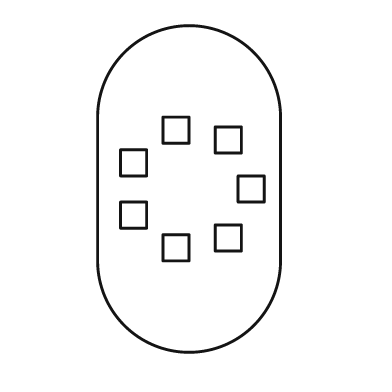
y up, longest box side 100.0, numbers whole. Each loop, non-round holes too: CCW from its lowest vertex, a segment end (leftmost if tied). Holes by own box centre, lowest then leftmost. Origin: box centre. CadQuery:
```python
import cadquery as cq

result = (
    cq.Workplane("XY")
    .moveTo(-28.0, -22.0)
    .threePointArc((0.0, -50.0), (28.0, -22.0))
    .lineTo(28.0, 22.0)
    .threePointArc((0.0, 50.0), (-28.0, 22.0))
    .close()
    .moveTo(-8.0, -22.0)
    .lineTo(0.0, -22.0)
    .lineTo(0.0, -14.0)
    .lineTo(-8.0, -14.0)
    .close()
    .moveTo(8.0, -19.0)
    .lineTo(16.0, -19.0)
    .lineTo(16.0, -11.0)
    .lineTo(8.0, -11.0)
    .close()
    .moveTo(-21.0, -12.0)
    .lineTo(-13.0, -12.0)
    .lineTo(-13.0, -4.0)
    .lineTo(-21.0, -4.0)
    .close()
    .moveTo(15.0, -4.0)
    .lineTo(23.0, -4.0)
    .lineTo(23.0, 4.0)
    .lineTo(15.0, 4.0)
    .close()
    .moveTo(-21.0, 4.0)
    .lineTo(-13.0, 4.0)
    .lineTo(-13.0, 12.0)
    .lineTo(-21.0, 12.0)
    .close()
    .moveTo(8.0, 11.0)
    .lineTo(16.0, 11.0)
    .lineTo(16.0, 19.0)
    .lineTo(8.0, 19.0)
    .close()
    .moveTo(-8.0, 14.0)
    .lineTo(0.0, 14.0)
    .lineTo(0.0, 22.0)
    .lineTo(-8.0, 22.0)
    .close()
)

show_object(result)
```